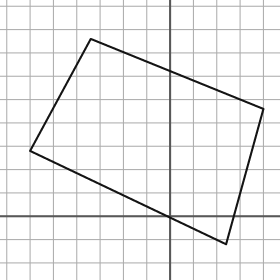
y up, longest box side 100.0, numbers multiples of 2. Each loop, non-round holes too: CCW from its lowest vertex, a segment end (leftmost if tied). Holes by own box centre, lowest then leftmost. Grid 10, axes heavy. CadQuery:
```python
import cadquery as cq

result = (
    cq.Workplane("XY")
    .moveTo(24.0, -12.0)
    .lineTo(40.0, 46.0)
    .lineTo(-34.0, 76.0)
    .lineTo(-60.0, 28.0)
    .close()
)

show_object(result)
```